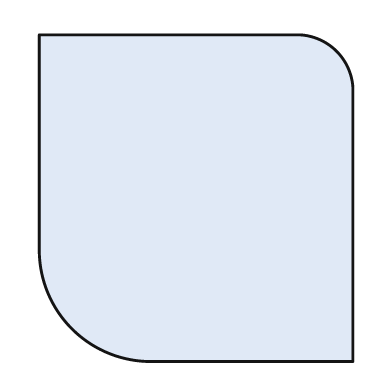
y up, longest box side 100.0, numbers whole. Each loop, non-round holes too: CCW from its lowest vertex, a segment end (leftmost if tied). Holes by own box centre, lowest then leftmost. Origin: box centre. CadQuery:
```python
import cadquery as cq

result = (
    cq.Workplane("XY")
    .moveTo(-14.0, -50.0)
    .lineTo(48.0, -50.0)
    .lineTo(48.0, 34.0)
    .threePointArc((43.0, 45.0), (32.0, 50.0))
    .lineTo(-48.0, 50.0)
    .lineTo(-48.0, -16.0)
    .threePointArc((-38.0, -40.0), (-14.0, -50.0))
    .close()
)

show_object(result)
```